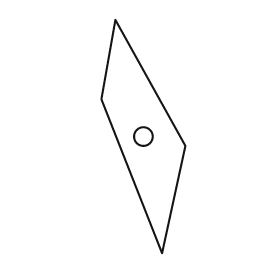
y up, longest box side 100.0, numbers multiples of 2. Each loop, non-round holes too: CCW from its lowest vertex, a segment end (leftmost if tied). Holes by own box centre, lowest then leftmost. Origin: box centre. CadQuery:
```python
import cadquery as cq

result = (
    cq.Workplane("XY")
    .moveTo(8.0, -50.0)
    .lineTo(18.0, -4.0)
    .lineTo(-12.0, 50.0)
    .lineTo(-18.0, 16.0)
    .close()
    .moveTo(0.0, 0.0)
    .circle(4.0)
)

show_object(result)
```